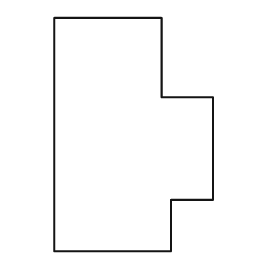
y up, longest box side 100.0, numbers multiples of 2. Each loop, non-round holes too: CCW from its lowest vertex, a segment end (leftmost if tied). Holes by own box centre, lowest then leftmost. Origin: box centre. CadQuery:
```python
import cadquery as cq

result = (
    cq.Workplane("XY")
    .moveTo(-34.0, -50.0)
    .lineTo(16.0, -50.0)
    .lineTo(16.0, -28.0)
    .lineTo(34.0, -28.0)
    .lineTo(34.0, 16.0)
    .lineTo(12.0, 16.0)
    .lineTo(12.0, 50.0)
    .lineTo(-34.0, 50.0)
    .close()
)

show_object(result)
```